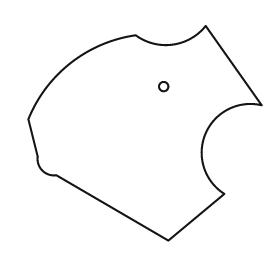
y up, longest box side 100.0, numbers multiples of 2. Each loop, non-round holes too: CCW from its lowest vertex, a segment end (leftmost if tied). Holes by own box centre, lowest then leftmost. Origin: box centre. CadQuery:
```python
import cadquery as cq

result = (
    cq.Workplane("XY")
    .moveTo(10.0, -46.0)
    .lineTo(34.0, -26.0)
    .threePointArc((26.0, 0.0), (50.0, 12.0))
    .lineTo(26.0, 46.0)
    .threePointArc((12.0, 38.0), (-4.0, 42.0))
    .threePointArc((-32.0, 30.0), (-50.0, 6.0))
    .lineTo(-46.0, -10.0)
    .threePointArc((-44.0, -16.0), (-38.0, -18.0))
    .close()
    .moveTo(8.0, 20.0)
    .circle(2.0)
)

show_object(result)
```